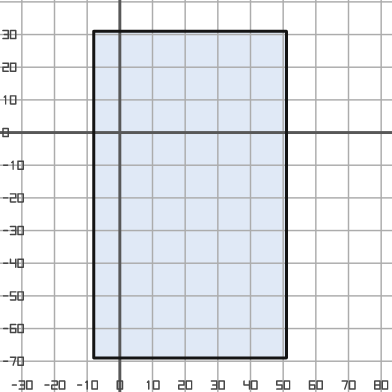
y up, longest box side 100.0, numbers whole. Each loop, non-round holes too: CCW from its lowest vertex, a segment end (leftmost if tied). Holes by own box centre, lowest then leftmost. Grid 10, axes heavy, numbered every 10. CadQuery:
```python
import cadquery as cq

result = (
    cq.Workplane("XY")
    .moveTo(-8.0, -69.0)
    .lineTo(51.0, -69.0)
    .lineTo(51.0, 31.0)
    .lineTo(-8.0, 31.0)
    .close()
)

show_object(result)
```